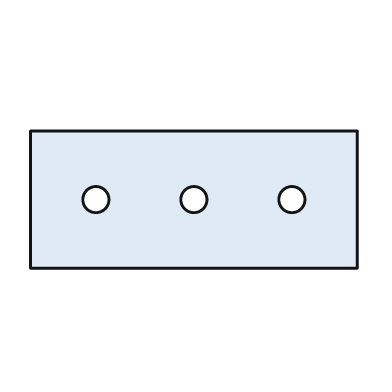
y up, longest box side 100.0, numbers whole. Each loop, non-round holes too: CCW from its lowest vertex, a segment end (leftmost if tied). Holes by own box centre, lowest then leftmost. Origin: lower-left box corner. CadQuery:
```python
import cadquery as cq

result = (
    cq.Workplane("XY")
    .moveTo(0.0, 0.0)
    .lineTo(100.0, 0.0)
    .lineTo(100.0, 42.0)
    .lineTo(0.0, 42.0)
    .close()
    .moveTo(20.0, 21.0)
    .circle(4.0)
    .moveTo(50.0, 21.0)
    .circle(4.0)
    .moveTo(80.0, 21.0)
    .circle(4.0)
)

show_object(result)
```